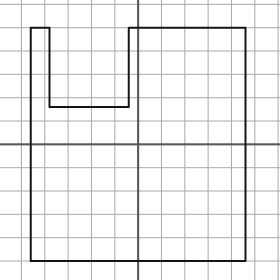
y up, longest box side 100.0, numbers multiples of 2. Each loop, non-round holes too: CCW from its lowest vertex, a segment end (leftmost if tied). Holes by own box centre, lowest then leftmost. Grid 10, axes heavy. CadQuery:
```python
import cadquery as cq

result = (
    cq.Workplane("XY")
    .moveTo(-46.0, -50.0)
    .lineTo(46.0, -50.0)
    .lineTo(46.0, 50.0)
    .lineTo(-4.0, 50.0)
    .lineTo(-4.0, 16.0)
    .lineTo(-38.0, 16.0)
    .lineTo(-38.0, 50.0)
    .lineTo(-46.0, 50.0)
    .close()
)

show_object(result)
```